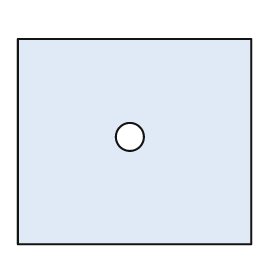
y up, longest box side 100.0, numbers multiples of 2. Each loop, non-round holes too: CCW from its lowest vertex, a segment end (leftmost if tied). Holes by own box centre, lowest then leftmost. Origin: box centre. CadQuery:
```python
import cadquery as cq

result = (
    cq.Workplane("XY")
    .moveTo(-50.0, -44.0)
    .lineTo(50.0, -44.0)
    .lineTo(50.0, 44.0)
    .lineTo(-50.0, 44.0)
    .close()
    .moveTo(-2.0, 2.0)
    .circle(6.0)
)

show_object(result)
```